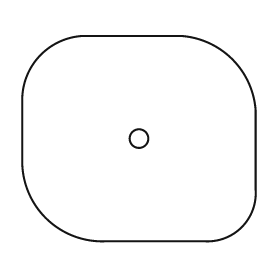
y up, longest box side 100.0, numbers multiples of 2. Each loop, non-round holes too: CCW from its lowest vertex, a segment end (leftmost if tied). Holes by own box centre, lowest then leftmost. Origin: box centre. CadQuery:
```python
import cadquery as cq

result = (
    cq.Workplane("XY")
    .moveTo(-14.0, -44.0)
    .lineTo(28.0, -44.0)
    .threePointArc((44.0, -38.0), (50.0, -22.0))
    .lineTo(50.0, 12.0)
    .threePointArc((40.0, 34.0), (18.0, 44.0))
    .lineTo(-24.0, 44.0)
    .threePointArc((-42.0, 36.0), (-50.0, 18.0))
    .lineTo(-50.0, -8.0)
    .threePointArc((-40.0, -34.0), (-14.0, -44.0))
    .close()
    .moveTo(0.0, 0.0)
    .circle(4.0)
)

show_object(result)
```